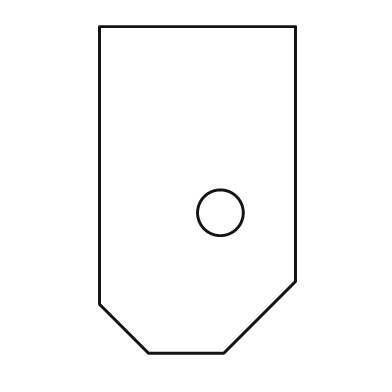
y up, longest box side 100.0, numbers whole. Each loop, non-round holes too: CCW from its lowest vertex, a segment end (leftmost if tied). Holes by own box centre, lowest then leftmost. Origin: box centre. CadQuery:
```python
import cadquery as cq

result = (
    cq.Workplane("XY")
    .moveTo(-15.0, -50.0)
    .lineTo(8.0, -50.0)
    .lineTo(30.0, -28.0)
    .lineTo(30.0, 50.0)
    .lineTo(-30.0, 50.0)
    .lineTo(-30.0, -35.0)
    .close()
    .moveTo(7.0, -7.0)
    .circle(7.0)
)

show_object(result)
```